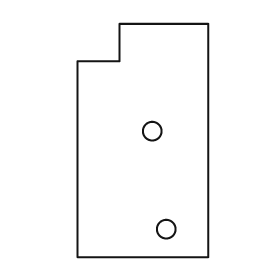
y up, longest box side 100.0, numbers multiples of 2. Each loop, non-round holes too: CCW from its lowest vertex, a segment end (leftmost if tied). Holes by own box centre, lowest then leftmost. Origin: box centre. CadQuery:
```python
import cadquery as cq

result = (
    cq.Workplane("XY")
    .moveTo(-28.0, -50.0)
    .lineTo(28.0, -50.0)
    .lineTo(28.0, 50.0)
    .lineTo(-10.0, 50.0)
    .lineTo(-10.0, 34.0)
    .lineTo(-28.0, 34.0)
    .close()
    .moveTo(10.0, -38.0)
    .circle(4.0)
    .moveTo(4.0, 4.0)
    .circle(4.0)
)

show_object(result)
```